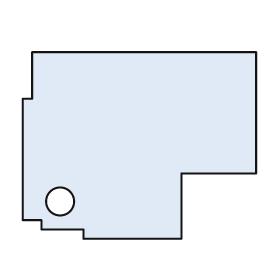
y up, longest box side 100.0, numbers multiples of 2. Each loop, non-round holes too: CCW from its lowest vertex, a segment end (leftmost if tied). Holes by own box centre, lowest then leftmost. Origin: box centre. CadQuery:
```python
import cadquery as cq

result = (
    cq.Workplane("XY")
    .moveTo(-24.0, -40.0)
    .lineTo(18.0, -40.0)
    .lineTo(18.0, -12.0)
    .lineTo(50.0, -12.0)
    .lineTo(50.0, 40.0)
    .lineTo(-46.0, 40.0)
    .lineTo(-46.0, 20.0)
    .lineTo(-50.0, 20.0)
    .lineTo(-50.0, -32.0)
    .lineTo(-42.0, -32.0)
    .lineTo(-42.0, -36.0)
    .lineTo(-24.0, -36.0)
    .close()
    .moveTo(-34.0, -24.0)
    .circle(6.0)
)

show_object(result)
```